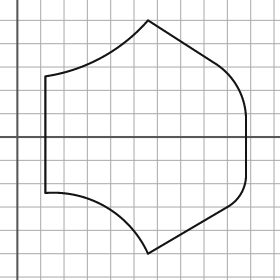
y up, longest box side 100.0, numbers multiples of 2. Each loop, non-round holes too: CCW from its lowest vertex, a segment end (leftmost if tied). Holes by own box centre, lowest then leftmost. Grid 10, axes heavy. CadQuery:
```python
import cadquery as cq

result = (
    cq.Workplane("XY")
    .moveTo(56.0, -50.0)
    .lineTo(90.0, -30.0)
    .threePointArc((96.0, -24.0), (98.0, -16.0))
    .lineTo(98.0, 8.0)
    .threePointArc((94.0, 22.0), (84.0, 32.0))
    .lineTo(56.0, 50.0)
    .threePointArc((36.0, 34.0), (12.0, 26.0))
    .lineTo(12.0, -24.0)
    .threePointArc((38.0, -30.0), (56.0, -50.0))
    .close()
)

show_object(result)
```